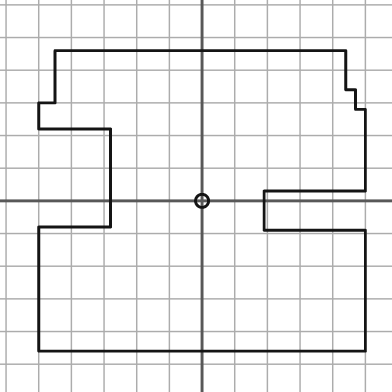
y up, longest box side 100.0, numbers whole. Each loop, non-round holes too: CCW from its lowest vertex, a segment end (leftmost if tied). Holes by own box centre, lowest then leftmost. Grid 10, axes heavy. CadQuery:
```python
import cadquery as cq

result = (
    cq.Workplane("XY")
    .moveTo(-50.0, -46.0)
    .lineTo(50.0, -46.0)
    .lineTo(50.0, -9.0)
    .lineTo(19.0, -9.0)
    .lineTo(19.0, 3.0)
    .lineTo(50.0, 3.0)
    .lineTo(50.0, 28.0)
    .lineTo(47.0, 28.0)
    .lineTo(47.0, 34.0)
    .lineTo(44.0, 34.0)
    .lineTo(44.0, 46.0)
    .lineTo(-45.0, 46.0)
    .lineTo(-45.0, 30.0)
    .lineTo(-50.0, 30.0)
    .lineTo(-50.0, 22.0)
    .lineTo(-28.0, 22.0)
    .lineTo(-28.0, -8.0)
    .lineTo(-50.0, -8.0)
    .close()
    .moveTo(0.0, 0.0)
    .circle(2.0)
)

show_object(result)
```